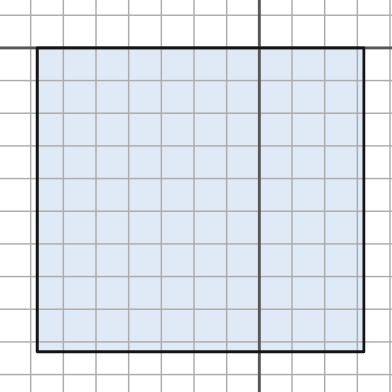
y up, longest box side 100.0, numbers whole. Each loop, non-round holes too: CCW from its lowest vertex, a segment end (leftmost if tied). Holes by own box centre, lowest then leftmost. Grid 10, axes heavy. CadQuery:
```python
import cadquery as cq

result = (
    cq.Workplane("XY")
    .moveTo(-68.0, -93.0)
    .lineTo(32.0, -93.0)
    .lineTo(32.0, 0.0)
    .lineTo(-68.0, 0.0)
    .close()
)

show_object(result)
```